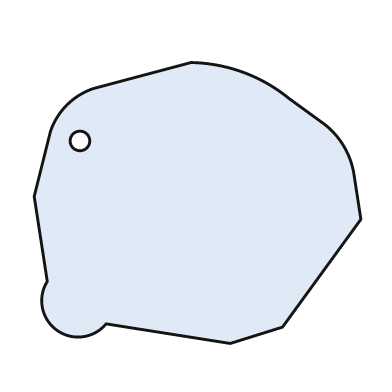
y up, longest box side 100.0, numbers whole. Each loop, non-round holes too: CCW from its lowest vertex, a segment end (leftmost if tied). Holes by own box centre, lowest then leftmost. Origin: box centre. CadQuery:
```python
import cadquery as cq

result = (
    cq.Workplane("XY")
    .moveTo(10.0, -43.0)
    .lineTo(26.0, -38.0)
    .lineTo(50.0, -5.0)
    .lineTo(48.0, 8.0)
    .threePointArc((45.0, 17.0), (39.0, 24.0))
    .lineTo(28.0, 32.0)
    .threePointArc((14.0, 40.0), (-2.0, 43.0))
    .lineTo(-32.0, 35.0)
    .threePointArc((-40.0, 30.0), (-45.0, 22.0))
    .lineTo(-50.0, 2.0)
    .lineTo(-46.0, -24.0)
    .threePointArc((-43.0, -39.0), (-28.0, -37.0))
    .close()
    .moveTo(-36.0, 19.0)
    .circle(3.0)
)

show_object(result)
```